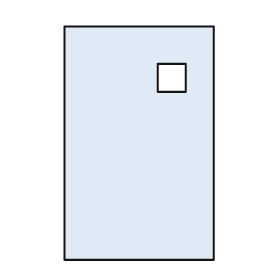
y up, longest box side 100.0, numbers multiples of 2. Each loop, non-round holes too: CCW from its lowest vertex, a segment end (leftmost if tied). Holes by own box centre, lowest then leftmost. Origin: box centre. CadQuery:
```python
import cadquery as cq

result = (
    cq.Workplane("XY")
    .moveTo(-32.0, -50.0)
    .lineTo(32.0, -50.0)
    .lineTo(32.0, 50.0)
    .lineTo(-32.0, 50.0)
    .close()
    .moveTo(8.0, 22.0)
    .lineTo(20.0, 22.0)
    .lineTo(20.0, 34.0)
    .lineTo(8.0, 34.0)
    .close()
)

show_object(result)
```